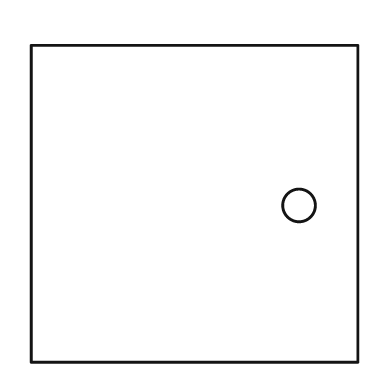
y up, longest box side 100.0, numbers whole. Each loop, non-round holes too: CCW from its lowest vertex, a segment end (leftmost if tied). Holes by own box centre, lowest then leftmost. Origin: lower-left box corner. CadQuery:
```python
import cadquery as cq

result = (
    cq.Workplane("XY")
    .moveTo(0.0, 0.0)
    .lineTo(100.0, 0.0)
    .lineTo(100.0, 97.0)
    .lineTo(0.0, 97.0)
    .close()
    .moveTo(82.0, 48.0)
    .circle(5.0)
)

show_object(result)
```